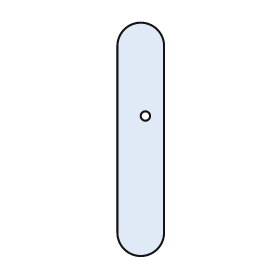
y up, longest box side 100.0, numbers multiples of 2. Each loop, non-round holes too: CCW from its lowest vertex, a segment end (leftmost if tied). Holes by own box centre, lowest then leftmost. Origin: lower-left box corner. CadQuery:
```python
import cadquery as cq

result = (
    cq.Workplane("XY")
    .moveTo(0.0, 10.0)
    .threePointArc((10.0, 0.0), (20.0, 10.0))
    .lineTo(20.0, 90.0)
    .threePointArc((10.0, 100.0), (0.0, 90.0))
    .close()
    .moveTo(12.0, 60.0)
    .circle(2.0)
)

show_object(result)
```